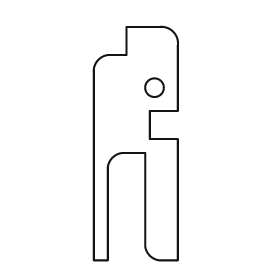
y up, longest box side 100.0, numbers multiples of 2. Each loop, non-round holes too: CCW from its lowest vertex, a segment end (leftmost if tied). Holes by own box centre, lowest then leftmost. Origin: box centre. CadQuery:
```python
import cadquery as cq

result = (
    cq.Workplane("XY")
    .moveTo(-18.0, -50.0)
    .lineTo(-12.0, -50.0)
    .lineTo(-12.0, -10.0)
    .threePointArc((-10.0, -6.0), (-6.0, -4.0))
    .lineTo(4.0, -4.0)
    .lineTo(4.0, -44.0)
    .threePointArc((6.0, -48.0), (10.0, -50.0))
    .lineTo(18.0, -50.0)
    .lineTo(18.0, 2.0)
    .lineTo(6.0, 2.0)
    .lineTo(6.0, 14.0)
    .lineTo(18.0, 14.0)
    .lineTo(18.0, 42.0)
    .threePointArc((16.0, 48.0), (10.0, 50.0))
    .lineTo(-4.0, 50.0)
    .lineTo(-4.0, 38.0)
    .lineTo(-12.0, 38.0)
    .threePointArc((-16.0, 36.0), (-18.0, 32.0))
    .close()
    .moveTo(8.0, 24.0)
    .circle(4.0)
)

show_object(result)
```